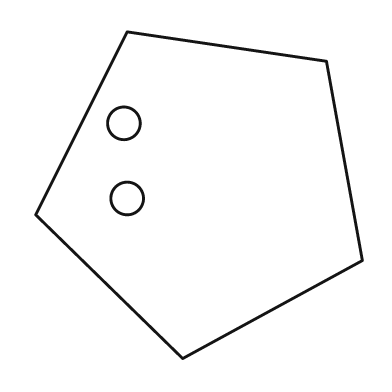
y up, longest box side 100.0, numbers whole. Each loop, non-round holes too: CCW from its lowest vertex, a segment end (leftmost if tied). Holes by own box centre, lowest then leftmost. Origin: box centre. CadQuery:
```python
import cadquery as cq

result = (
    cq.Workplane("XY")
    .moveTo(-5.0, -50.0)
    .lineTo(50.0, -20.0)
    .lineTo(39.0, 41.0)
    .lineTo(-22.0, 50.0)
    .lineTo(-50.0, -6.0)
    .close()
    .moveTo(-22.0, -1.0)
    .circle(5.0)
    .moveTo(-23.0, 22.0)
    .circle(5.0)
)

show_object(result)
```